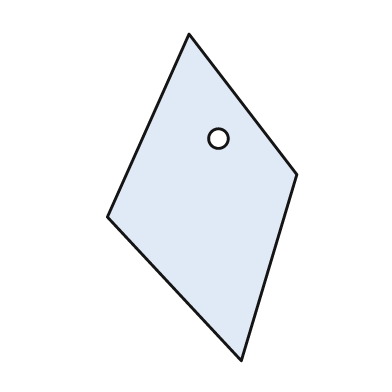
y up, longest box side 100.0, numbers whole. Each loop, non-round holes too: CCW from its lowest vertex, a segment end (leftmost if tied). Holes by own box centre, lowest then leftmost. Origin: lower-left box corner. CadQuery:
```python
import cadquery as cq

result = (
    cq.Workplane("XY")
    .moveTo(41.0, 0.0)
    .lineTo(58.0, 57.0)
    .lineTo(25.0, 100.0)
    .lineTo(0.0, 44.0)
    .close()
    .moveTo(34.0, 68.0)
    .circle(3.0)
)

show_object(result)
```